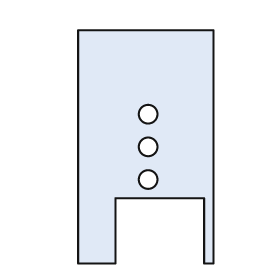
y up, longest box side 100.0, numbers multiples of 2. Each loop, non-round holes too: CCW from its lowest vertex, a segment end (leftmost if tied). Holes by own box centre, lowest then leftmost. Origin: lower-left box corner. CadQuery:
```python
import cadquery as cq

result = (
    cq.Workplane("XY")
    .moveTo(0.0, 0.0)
    .lineTo(16.0, 0.0)
    .lineTo(16.0, 28.0)
    .lineTo(54.0, 28.0)
    .lineTo(54.0, 0.0)
    .lineTo(58.0, 0.0)
    .lineTo(58.0, 100.0)
    .lineTo(0.0, 100.0)
    .close()
    .moveTo(30.0, 36.0)
    .circle(4.0)
    .moveTo(30.0, 50.0)
    .circle(4.0)
    .moveTo(30.0, 64.0)
    .circle(4.0)
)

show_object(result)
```